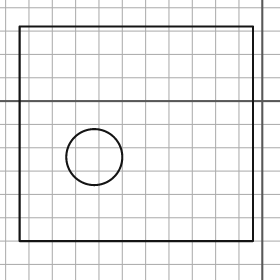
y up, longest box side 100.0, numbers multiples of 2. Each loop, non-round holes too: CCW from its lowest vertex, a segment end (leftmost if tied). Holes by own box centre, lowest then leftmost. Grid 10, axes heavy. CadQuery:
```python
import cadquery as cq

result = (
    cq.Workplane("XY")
    .moveTo(-104.0, -60.0)
    .lineTo(-4.0, -60.0)
    .lineTo(-4.0, 32.0)
    .lineTo(-104.0, 32.0)
    .close()
    .moveTo(-72.0, -24.0)
    .circle(12.0)
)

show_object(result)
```